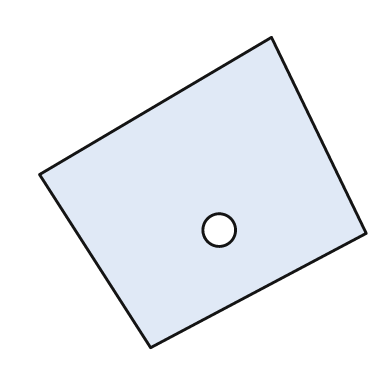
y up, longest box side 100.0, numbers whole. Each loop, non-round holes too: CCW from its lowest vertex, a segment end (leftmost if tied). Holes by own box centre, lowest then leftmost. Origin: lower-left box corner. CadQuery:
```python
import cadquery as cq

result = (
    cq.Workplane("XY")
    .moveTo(34.0, 0.0)
    .lineTo(100.0, 35.0)
    .lineTo(71.0, 95.0)
    .lineTo(0.0, 53.0)
    .close()
    .moveTo(55.0, 36.0)
    .circle(5.0)
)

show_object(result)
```